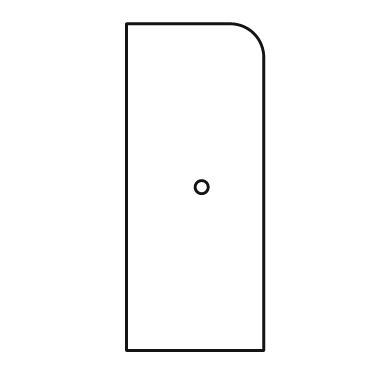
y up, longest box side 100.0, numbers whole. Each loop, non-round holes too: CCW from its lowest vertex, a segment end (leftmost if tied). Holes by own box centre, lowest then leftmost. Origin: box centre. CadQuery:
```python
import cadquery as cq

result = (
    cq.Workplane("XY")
    .moveTo(-21.0, -50.0)
    .lineTo(21.0, -50.0)
    .lineTo(21.0, 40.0)
    .threePointArc((18.0, 47.0), (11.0, 50.0))
    .lineTo(-21.0, 50.0)
    .close()
    .moveTo(2.0, 0.0)
    .circle(2.0)
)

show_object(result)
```